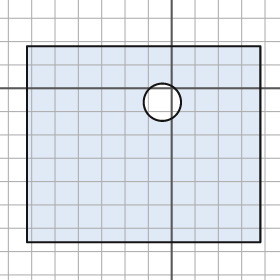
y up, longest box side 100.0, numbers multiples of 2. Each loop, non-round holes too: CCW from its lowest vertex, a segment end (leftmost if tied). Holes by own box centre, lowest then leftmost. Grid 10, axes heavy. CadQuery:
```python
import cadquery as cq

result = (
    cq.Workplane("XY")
    .moveTo(-62.0, -66.0)
    .lineTo(38.0, -66.0)
    .lineTo(38.0, 18.0)
    .lineTo(-62.0, 18.0)
    .close()
    .moveTo(-4.0, -6.0)
    .circle(8.0)
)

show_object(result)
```